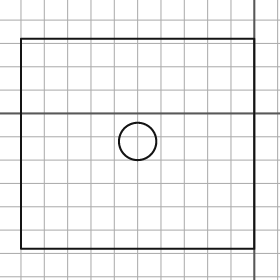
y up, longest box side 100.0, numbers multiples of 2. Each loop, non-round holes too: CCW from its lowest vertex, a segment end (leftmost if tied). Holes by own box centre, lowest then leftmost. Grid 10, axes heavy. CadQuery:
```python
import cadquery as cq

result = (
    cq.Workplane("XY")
    .moveTo(-100.0, -58.0)
    .lineTo(0.0, -58.0)
    .lineTo(0.0, 32.0)
    .lineTo(-100.0, 32.0)
    .close()
    .moveTo(-50.0, -12.0)
    .circle(8.0)
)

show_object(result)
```